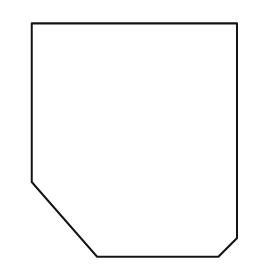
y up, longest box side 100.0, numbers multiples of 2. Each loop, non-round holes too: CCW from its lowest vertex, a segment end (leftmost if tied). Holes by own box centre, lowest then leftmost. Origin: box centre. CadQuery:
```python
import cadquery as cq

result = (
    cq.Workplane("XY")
    .moveTo(-16.0, -50.0)
    .lineTo(36.0, -50.0)
    .lineTo(44.0, -42.0)
    .lineTo(44.0, 50.0)
    .lineTo(-44.0, 50.0)
    .lineTo(-44.0, -18.0)
    .close()
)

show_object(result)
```